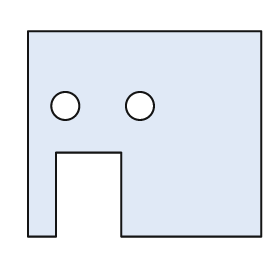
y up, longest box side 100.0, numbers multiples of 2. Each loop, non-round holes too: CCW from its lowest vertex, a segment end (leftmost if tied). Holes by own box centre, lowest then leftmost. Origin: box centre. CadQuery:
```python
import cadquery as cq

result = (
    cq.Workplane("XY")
    .moveTo(-50.0, -44.0)
    .lineTo(-38.0, -44.0)
    .lineTo(-38.0, -8.0)
    .lineTo(-10.0, -8.0)
    .lineTo(-10.0, -44.0)
    .lineTo(50.0, -44.0)
    .lineTo(50.0, 44.0)
    .lineTo(-50.0, 44.0)
    .close()
    .moveTo(-34.0, 12.0)
    .circle(6.0)
    .moveTo(-2.0, 12.0)
    .circle(6.0)
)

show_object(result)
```